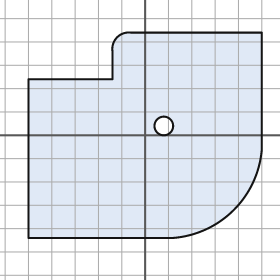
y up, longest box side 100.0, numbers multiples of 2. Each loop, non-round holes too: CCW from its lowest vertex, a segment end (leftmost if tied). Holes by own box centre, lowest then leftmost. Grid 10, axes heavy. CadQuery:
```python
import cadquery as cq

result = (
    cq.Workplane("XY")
    .moveTo(-50.0, -44.0)
    .lineTo(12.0, -44.0)
    .threePointArc((38.0, -32.0), (50.0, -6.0))
    .lineTo(50.0, 44.0)
    .lineTo(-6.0, 44.0)
    .threePointArc((-12.0, 42.0), (-14.0, 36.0))
    .lineTo(-14.0, 24.0)
    .lineTo(-50.0, 24.0)
    .close()
    .moveTo(8.0, 4.0)
    .circle(4.0)
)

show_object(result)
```